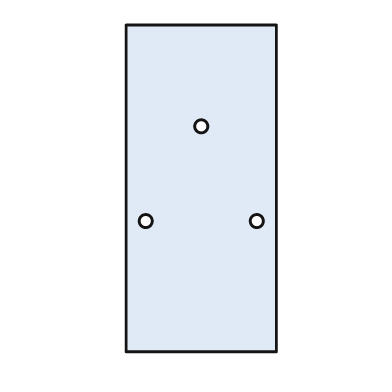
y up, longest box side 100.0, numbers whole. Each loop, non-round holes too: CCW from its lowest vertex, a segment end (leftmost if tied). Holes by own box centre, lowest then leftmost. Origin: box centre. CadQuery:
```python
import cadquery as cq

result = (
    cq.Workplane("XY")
    .moveTo(-23.0, -50.0)
    .lineTo(23.0, -50.0)
    .lineTo(23.0, 50.0)
    .lineTo(-23.0, 50.0)
    .close()
    .moveTo(-17.0, -10.0)
    .circle(2.0)
    .moveTo(17.0, -10.0)
    .circle(2.0)
    .moveTo(0.0, 19.0)
    .circle(2.0)
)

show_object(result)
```